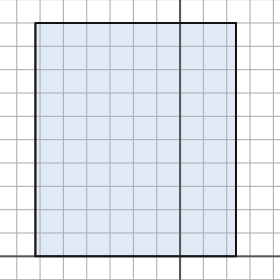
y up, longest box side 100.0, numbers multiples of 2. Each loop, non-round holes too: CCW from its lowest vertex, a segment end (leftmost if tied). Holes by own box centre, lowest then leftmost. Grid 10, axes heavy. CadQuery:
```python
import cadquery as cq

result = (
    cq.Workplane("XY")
    .moveTo(-62.0, 0.0)
    .lineTo(24.0, 0.0)
    .lineTo(24.0, 100.0)
    .lineTo(-62.0, 100.0)
    .close()
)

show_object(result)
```